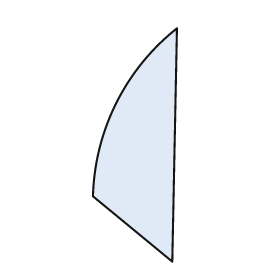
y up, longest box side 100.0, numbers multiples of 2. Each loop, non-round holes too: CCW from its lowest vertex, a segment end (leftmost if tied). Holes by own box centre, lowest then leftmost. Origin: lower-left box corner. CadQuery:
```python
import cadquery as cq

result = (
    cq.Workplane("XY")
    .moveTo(34.0, 0.0)
    .lineTo(36.0, 100.0)
    .threePointArc((10.0, 68.0), (0.0, 28.0))
    .close()
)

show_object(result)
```